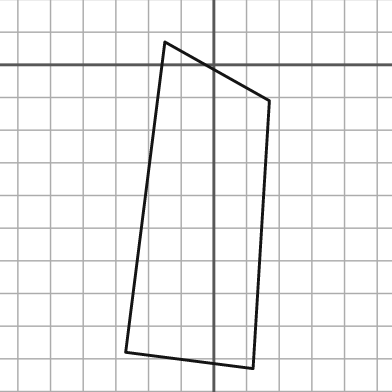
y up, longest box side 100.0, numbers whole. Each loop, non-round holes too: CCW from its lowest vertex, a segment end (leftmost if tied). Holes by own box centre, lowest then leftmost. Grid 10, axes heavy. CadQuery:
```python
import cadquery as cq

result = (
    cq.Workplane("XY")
    .moveTo(12.0, -93.0)
    .lineTo(17.0, -11.0)
    .lineTo(-15.0, 7.0)
    .lineTo(-27.0, -88.0)
    .close()
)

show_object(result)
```